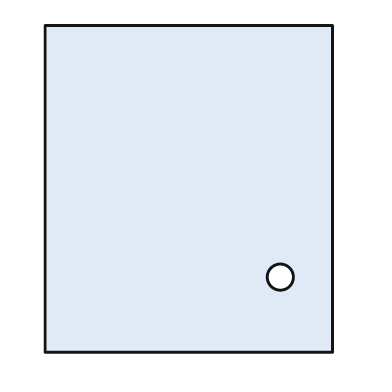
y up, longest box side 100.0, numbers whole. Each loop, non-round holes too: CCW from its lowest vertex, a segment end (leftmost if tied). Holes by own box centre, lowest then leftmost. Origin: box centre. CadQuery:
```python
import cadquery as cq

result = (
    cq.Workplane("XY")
    .moveTo(-44.0, -50.0)
    .lineTo(44.0, -50.0)
    .lineTo(44.0, 50.0)
    .lineTo(-44.0, 50.0)
    .close()
    .moveTo(28.0, -27.0)
    .circle(4.0)
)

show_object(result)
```